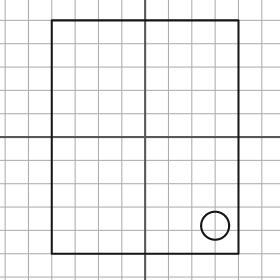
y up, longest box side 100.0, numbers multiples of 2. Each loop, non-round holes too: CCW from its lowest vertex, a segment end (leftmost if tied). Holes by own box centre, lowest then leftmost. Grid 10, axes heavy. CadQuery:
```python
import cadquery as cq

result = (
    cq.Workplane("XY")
    .moveTo(-40.0, -50.0)
    .lineTo(40.0, -50.0)
    .lineTo(40.0, 50.0)
    .lineTo(-40.0, 50.0)
    .close()
    .moveTo(30.0, -38.0)
    .circle(6.0)
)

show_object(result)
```